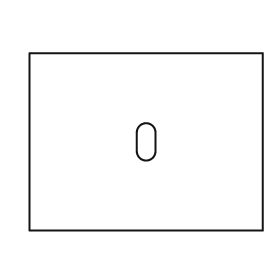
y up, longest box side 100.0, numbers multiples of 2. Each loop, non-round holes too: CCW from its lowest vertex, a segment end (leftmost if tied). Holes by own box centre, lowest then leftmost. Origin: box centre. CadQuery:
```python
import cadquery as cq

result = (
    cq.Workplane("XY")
    .moveTo(-50.0, -38.0)
    .lineTo(50.0, -38.0)
    .lineTo(50.0, 38.0)
    .lineTo(-50.0, 38.0)
    .close()
    .moveTo(-4.0, -4.0)
    .threePointArc((0.0, -8.0), (4.0, -4.0))
    .lineTo(4.0, 4.0)
    .threePointArc((0.0, 8.0), (-4.0, 4.0))
    .close()
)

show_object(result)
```